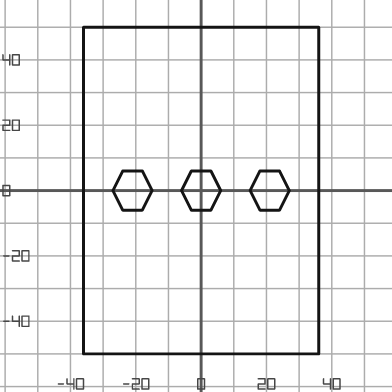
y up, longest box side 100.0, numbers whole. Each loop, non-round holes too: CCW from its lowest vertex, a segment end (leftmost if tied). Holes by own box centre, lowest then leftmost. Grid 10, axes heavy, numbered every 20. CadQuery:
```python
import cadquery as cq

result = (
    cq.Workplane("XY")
    .moveTo(-36.0, -50.0)
    .lineTo(36.0, -50.0)
    .lineTo(36.0, 50.0)
    .lineTo(-36.0, 50.0)
    .close()
    .moveTo(-24.0, -6.0)
    .lineTo(-18.0, -6.0)
    .lineTo(-15.0, 0.0)
    .lineTo(-18.0, 6.0)
    .lineTo(-24.0, 6.0)
    .lineTo(-27.0, 0.0)
    .close()
    .moveTo(-3.0, -6.0)
    .lineTo(3.0, -6.0)
    .lineTo(6.0, 0.0)
    .lineTo(3.0, 6.0)
    .lineTo(-3.0, 6.0)
    .lineTo(-6.0, 0.0)
    .close()
    .moveTo(18.0, -6.0)
    .lineTo(24.0, -6.0)
    .lineTo(27.0, 0.0)
    .lineTo(24.0, 6.0)
    .lineTo(18.0, 6.0)
    .lineTo(15.0, 0.0)
    .close()
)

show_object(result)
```